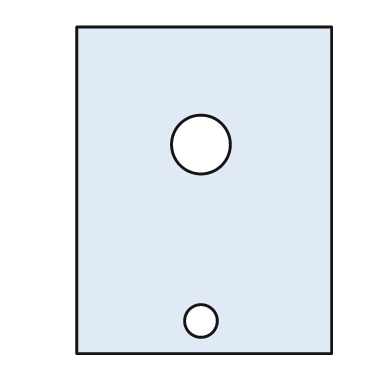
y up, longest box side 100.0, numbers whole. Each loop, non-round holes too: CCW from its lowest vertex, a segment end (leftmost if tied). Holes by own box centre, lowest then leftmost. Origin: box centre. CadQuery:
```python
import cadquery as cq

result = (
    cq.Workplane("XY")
    .moveTo(-39.0, -50.0)
    .lineTo(39.0, -50.0)
    .lineTo(39.0, 50.0)
    .lineTo(-39.0, 50.0)
    .close()
    .moveTo(-1.0, -40.0)
    .circle(5.0)
    .moveTo(-1.0, 14.0)
    .circle(9.0)
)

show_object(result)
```